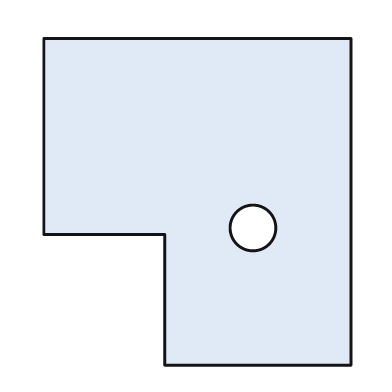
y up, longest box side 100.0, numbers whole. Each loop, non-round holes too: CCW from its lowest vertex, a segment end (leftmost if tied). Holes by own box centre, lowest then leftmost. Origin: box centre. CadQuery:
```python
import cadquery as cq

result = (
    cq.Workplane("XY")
    .moveTo(-10.0, -50.0)
    .lineTo(47.0, -50.0)
    .lineTo(47.0, 50.0)
    .lineTo(-47.0, 50.0)
    .lineTo(-47.0, -10.0)
    .lineTo(-10.0, -10.0)
    .close()
    .moveTo(17.0, -8.0)
    .circle(7.0)
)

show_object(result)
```